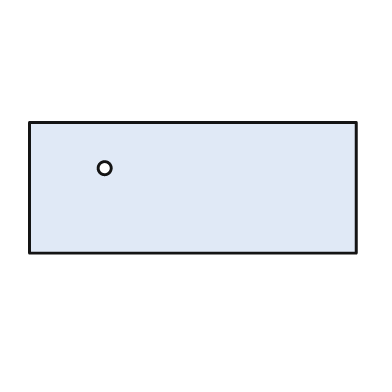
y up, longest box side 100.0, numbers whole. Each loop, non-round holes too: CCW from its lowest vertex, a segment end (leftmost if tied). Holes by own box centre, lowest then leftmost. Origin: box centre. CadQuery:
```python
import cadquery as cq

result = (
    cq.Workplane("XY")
    .moveTo(-50.0, -20.0)
    .lineTo(50.0, -20.0)
    .lineTo(50.0, 20.0)
    .lineTo(-50.0, 20.0)
    .close()
    .moveTo(-27.0, 6.0)
    .circle(2.0)
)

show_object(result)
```